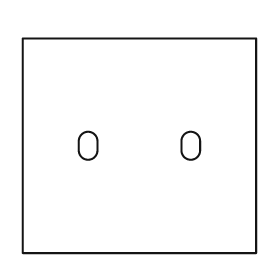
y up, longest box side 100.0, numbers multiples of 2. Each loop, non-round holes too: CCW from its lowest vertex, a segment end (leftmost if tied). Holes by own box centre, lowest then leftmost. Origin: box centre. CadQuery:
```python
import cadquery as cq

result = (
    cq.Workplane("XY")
    .moveTo(-50.0, -46.0)
    .lineTo(50.0, -46.0)
    .lineTo(50.0, 46.0)
    .lineTo(-50.0, 46.0)
    .close()
    .moveTo(-26.0, -2.0)
    .threePointArc((-22.0, -6.0), (-18.0, -2.0))
    .lineTo(-18.0, 2.0)
    .threePointArc((-22.0, 6.0), (-26.0, 2.0))
    .close()
    .moveTo(18.0, -2.0)
    .threePointArc((22.0, -6.0), (26.0, -2.0))
    .lineTo(26.0, 2.0)
    .threePointArc((22.0, 6.0), (18.0, 2.0))
    .close()
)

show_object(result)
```